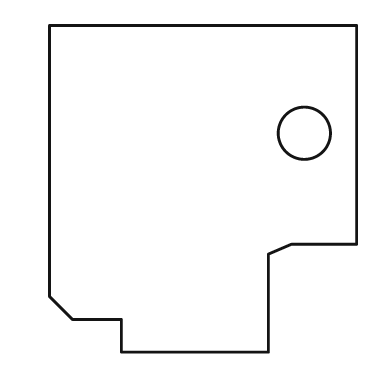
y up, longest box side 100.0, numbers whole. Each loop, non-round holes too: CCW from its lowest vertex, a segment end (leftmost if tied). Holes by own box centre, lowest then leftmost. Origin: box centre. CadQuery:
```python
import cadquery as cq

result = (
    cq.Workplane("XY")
    .moveTo(-25.0, -50.0)
    .lineTo(20.0, -50.0)
    .lineTo(20.0, -20.0)
    .lineTo(27.0, -17.0)
    .lineTo(47.0, -17.0)
    .lineTo(47.0, 50.0)
    .lineTo(-47.0, 50.0)
    .lineTo(-47.0, -33.0)
    .lineTo(-40.0, -40.0)
    .lineTo(-25.0, -40.0)
    .close()
    .moveTo(31.0, 17.0)
    .circle(8.0)
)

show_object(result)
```